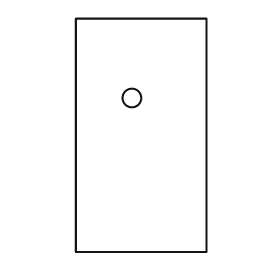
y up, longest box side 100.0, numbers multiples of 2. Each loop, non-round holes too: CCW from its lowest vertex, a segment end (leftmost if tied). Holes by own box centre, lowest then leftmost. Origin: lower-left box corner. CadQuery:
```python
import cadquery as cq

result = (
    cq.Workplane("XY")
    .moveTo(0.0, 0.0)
    .lineTo(56.0, 0.0)
    .lineTo(56.0, 100.0)
    .lineTo(0.0, 100.0)
    .close()
    .moveTo(24.0, 66.0)
    .circle(4.0)
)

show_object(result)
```